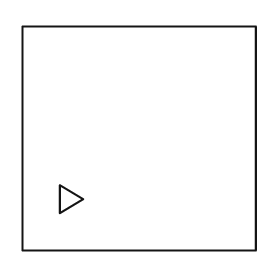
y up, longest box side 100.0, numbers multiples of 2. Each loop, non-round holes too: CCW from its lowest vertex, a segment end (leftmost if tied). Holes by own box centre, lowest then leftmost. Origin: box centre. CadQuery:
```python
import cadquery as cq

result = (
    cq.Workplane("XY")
    .moveTo(-50.0, -48.0)
    .lineTo(50.0, -48.0)
    .lineTo(50.0, 48.0)
    .lineTo(-50.0, 48.0)
    .close()
    .moveTo(-34.0, -32.0)
    .lineTo(-24.0, -26.0)
    .lineTo(-34.0, -20.0)
    .close()
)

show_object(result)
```